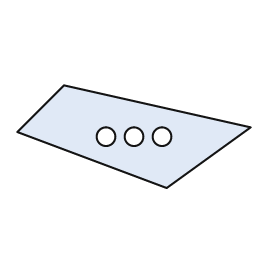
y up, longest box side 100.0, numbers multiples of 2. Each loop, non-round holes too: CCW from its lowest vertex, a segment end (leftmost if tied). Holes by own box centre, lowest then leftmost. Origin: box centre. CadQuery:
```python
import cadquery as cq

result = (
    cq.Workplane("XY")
    .moveTo(14.0, -22.0)
    .lineTo(50.0, 4.0)
    .lineTo(-30.0, 22.0)
    .lineTo(-50.0, 2.0)
    .close()
    .moveTo(-12.0, 0.0)
    .circle(4.0)
    .moveTo(0.0, 0.0)
    .circle(4.0)
    .moveTo(12.0, 0.0)
    .circle(4.0)
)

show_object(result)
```